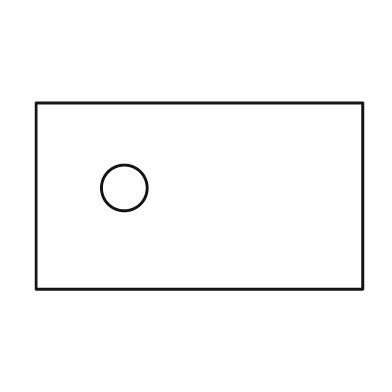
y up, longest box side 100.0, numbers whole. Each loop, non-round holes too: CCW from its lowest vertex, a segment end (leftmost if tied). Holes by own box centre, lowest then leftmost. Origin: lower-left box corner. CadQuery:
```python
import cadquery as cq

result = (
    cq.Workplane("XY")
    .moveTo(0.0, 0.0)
    .lineTo(100.0, 0.0)
    .lineTo(100.0, 57.0)
    .lineTo(0.0, 57.0)
    .close()
    .moveTo(27.0, 31.0)
    .circle(7.0)
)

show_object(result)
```